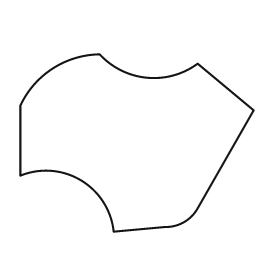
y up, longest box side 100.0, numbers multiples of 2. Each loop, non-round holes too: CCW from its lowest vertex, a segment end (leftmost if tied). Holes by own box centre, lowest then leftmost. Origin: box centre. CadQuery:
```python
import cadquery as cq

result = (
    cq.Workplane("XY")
    .moveTo(-10.0, -38.0)
    .lineTo(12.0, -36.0)
    .threePointArc((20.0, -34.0), (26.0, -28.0))
    .lineTo(50.0, 14.0)
    .lineTo(26.0, 34.0)
    .threePointArc((4.0, 28.0), (-16.0, 38.0))
    .threePointArc((-36.0, 32.0), (-50.0, 16.0))
    .lineTo(-50.0, -14.0)
    .threePointArc((-24.0, -16.0), (-10.0, -38.0))
    .close()
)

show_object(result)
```